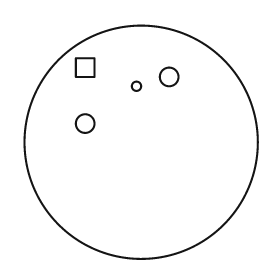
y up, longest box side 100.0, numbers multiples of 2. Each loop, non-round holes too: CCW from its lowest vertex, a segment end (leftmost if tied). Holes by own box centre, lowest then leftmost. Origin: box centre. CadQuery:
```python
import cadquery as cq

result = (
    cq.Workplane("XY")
    .moveTo(0.0, 0.0)
    .circle(50.0)
    .moveTo(-24.0, 8.0)
    .circle(4.0)
    .moveTo(-2.0, 24.0)
    .circle(2.0)
    .moveTo(12.0, 28.0)
    .circle(4.0)
    .moveTo(-28.0, 28.0)
    .lineTo(-20.0, 28.0)
    .lineTo(-20.0, 36.0)
    .lineTo(-28.0, 36.0)
    .close()
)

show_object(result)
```